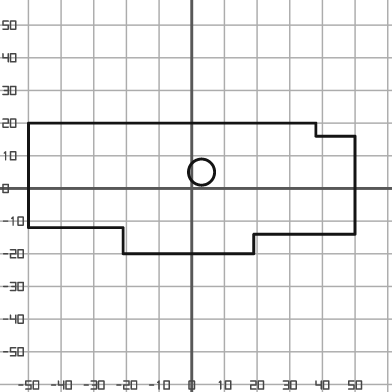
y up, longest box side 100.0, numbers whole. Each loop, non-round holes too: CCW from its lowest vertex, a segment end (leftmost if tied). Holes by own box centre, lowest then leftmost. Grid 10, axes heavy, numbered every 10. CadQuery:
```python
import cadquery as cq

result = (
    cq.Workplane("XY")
    .moveTo(-21.0, -20.0)
    .lineTo(19.0, -20.0)
    .lineTo(19.0, -14.0)
    .lineTo(50.0, -14.0)
    .lineTo(50.0, 16.0)
    .lineTo(38.0, 16.0)
    .lineTo(38.0, 20.0)
    .lineTo(-50.0, 20.0)
    .lineTo(-50.0, -12.0)
    .lineTo(-21.0, -12.0)
    .close()
    .moveTo(3.0, 5.0)
    .circle(4.0)
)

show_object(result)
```